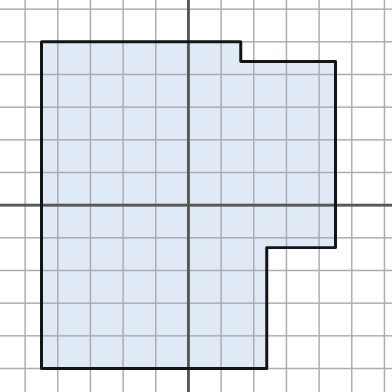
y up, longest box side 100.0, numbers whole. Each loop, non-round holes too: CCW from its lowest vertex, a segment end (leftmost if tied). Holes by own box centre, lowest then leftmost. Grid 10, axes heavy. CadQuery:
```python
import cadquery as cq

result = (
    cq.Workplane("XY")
    .moveTo(-45.0, -50.0)
    .lineTo(24.0, -50.0)
    .lineTo(24.0, -13.0)
    .lineTo(45.0, -13.0)
    .lineTo(45.0, 44.0)
    .lineTo(16.0, 44.0)
    .lineTo(16.0, 50.0)
    .lineTo(-45.0, 50.0)
    .close()
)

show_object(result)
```